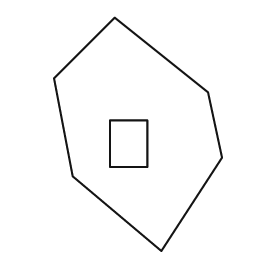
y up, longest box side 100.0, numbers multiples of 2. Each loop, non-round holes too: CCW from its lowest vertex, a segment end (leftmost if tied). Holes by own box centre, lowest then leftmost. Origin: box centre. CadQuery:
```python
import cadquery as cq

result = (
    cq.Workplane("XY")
    .moveTo(10.0, -50.0)
    .lineTo(36.0, -10.0)
    .lineTo(30.0, 18.0)
    .lineTo(-10.0, 50.0)
    .lineTo(-36.0, 24.0)
    .lineTo(-28.0, -18.0)
    .close()
    .moveTo(-12.0, -14.0)
    .lineTo(4.0, -14.0)
    .lineTo(4.0, 6.0)
    .lineTo(-12.0, 6.0)
    .close()
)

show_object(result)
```